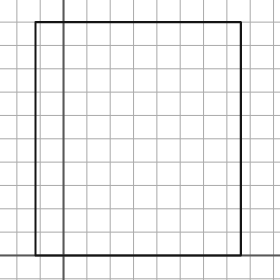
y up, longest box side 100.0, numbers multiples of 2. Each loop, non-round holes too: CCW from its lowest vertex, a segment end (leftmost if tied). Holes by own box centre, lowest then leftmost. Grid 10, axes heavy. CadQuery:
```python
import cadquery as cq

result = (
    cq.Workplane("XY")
    .moveTo(-12.0, 0.0)
    .lineTo(76.0, 0.0)
    .lineTo(76.0, 100.0)
    .lineTo(-12.0, 100.0)
    .close()
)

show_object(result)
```